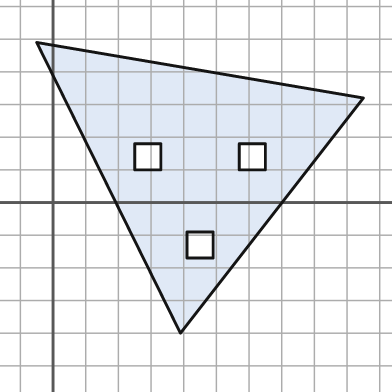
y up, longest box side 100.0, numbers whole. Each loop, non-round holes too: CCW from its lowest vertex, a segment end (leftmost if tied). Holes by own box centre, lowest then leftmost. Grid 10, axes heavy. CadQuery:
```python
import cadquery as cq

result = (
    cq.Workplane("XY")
    .moveTo(39.0, -40.0)
    .lineTo(95.0, 32.0)
    .lineTo(-5.0, 49.0)
    .close()
    .moveTo(41.0, -17.0)
    .lineTo(49.0, -17.0)
    .lineTo(49.0, -9.0)
    .lineTo(41.0, -9.0)
    .close()
    .moveTo(25.0, 10.0)
    .lineTo(33.0, 10.0)
    .lineTo(33.0, 18.0)
    .lineTo(25.0, 18.0)
    .close()
    .moveTo(57.0, 10.0)
    .lineTo(65.0, 10.0)
    .lineTo(65.0, 18.0)
    .lineTo(57.0, 18.0)
    .close()
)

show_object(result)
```